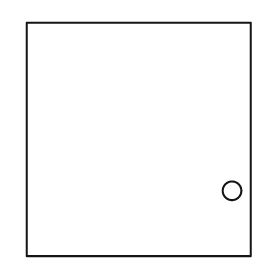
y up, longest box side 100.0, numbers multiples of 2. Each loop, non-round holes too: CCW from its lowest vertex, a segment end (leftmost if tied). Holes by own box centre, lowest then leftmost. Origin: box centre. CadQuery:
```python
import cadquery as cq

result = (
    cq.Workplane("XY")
    .moveTo(-48.0, -50.0)
    .lineTo(48.0, -50.0)
    .lineTo(48.0, 50.0)
    .lineTo(-48.0, 50.0)
    .close()
    .moveTo(40.0, -22.0)
    .circle(4.0)
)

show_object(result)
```